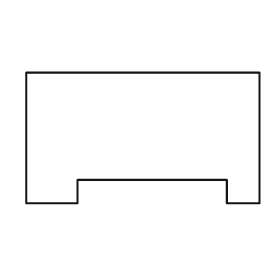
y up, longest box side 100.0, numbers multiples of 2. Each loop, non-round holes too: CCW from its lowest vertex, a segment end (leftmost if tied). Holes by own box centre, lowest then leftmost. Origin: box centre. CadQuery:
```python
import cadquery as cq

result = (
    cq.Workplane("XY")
    .moveTo(-50.0, -28.0)
    .lineTo(-28.0, -28.0)
    .lineTo(-28.0, -18.0)
    .lineTo(36.0, -18.0)
    .lineTo(36.0, -28.0)
    .lineTo(50.0, -28.0)
    .lineTo(50.0, 28.0)
    .lineTo(-50.0, 28.0)
    .close()
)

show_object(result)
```